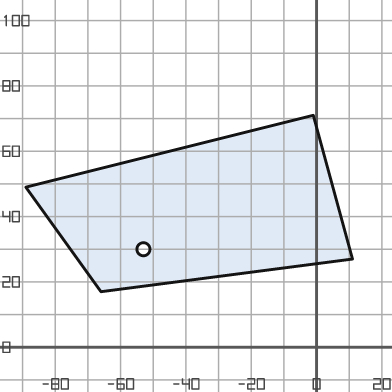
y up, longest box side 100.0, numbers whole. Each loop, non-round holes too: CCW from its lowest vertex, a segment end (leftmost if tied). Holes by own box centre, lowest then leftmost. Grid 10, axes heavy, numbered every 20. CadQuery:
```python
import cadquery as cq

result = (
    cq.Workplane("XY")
    .moveTo(-66.0, 17.0)
    .lineTo(11.0, 27.0)
    .lineTo(-1.0, 71.0)
    .lineTo(-89.0, 49.0)
    .close()
    .moveTo(-53.0, 30.0)
    .circle(2.0)
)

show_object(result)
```